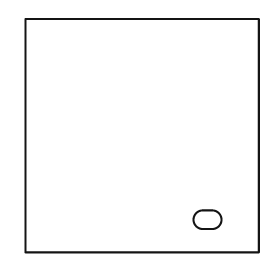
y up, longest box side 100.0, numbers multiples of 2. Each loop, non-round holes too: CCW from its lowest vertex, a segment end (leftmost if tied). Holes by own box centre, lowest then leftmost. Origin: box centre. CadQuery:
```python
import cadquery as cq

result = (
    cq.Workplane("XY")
    .moveTo(-50.0, -50.0)
    .lineTo(50.0, -50.0)
    .lineTo(50.0, 50.0)
    .lineTo(-50.0, 50.0)
    .close()
    .moveTo(26.0, -40.0)
    .lineTo(30.0, -40.0)
    .threePointArc((34.0, -36.0), (30.0, -32.0))
    .lineTo(26.0, -32.0)
    .threePointArc((22.0, -36.0), (26.0, -40.0))
    .close()
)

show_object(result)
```